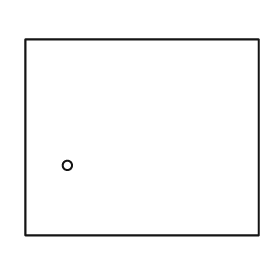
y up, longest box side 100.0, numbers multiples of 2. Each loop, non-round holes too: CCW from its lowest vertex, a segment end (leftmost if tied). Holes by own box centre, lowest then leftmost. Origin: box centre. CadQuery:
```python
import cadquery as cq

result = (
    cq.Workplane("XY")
    .moveTo(-50.0, -42.0)
    .lineTo(50.0, -42.0)
    .lineTo(50.0, 42.0)
    .lineTo(-50.0, 42.0)
    .close()
    .moveTo(-32.0, -12.0)
    .circle(2.0)
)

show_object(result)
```